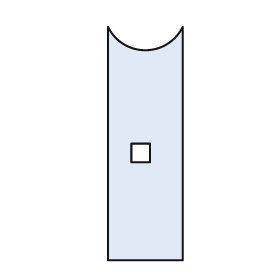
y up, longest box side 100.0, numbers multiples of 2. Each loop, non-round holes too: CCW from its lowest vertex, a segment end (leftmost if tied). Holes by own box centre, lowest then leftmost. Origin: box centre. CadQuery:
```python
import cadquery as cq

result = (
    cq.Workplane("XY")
    .moveTo(-16.0, -50.0)
    .lineTo(16.0, -50.0)
    .lineTo(16.0, 50.0)
    .threePointArc((0.0, 40.0), (-16.0, 50.0))
    .close()
    .moveTo(-6.0, -8.0)
    .lineTo(2.0, -8.0)
    .lineTo(2.0, 0.0)
    .lineTo(-6.0, 0.0)
    .close()
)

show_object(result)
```